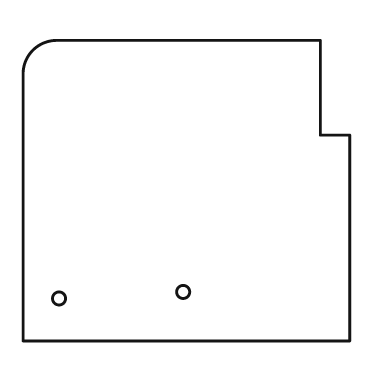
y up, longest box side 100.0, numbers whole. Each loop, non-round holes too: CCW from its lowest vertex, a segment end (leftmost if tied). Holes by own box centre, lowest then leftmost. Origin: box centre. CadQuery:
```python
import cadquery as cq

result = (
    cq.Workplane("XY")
    .moveTo(-50.0, -46.0)
    .lineTo(50.0, -46.0)
    .lineTo(50.0, 17.0)
    .lineTo(41.0, 17.0)
    .lineTo(41.0, 46.0)
    .lineTo(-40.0, 46.0)
    .threePointArc((-47.0, 43.0), (-50.0, 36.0))
    .close()
    .moveTo(-39.0, -33.0)
    .circle(2.0)
    .moveTo(-1.0, -31.0)
    .circle(2.0)
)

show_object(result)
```